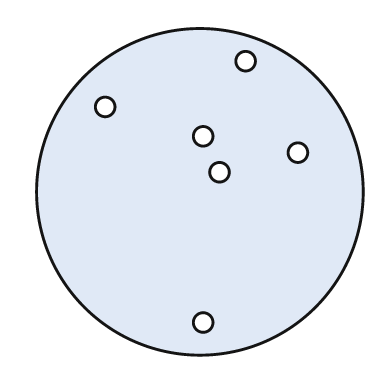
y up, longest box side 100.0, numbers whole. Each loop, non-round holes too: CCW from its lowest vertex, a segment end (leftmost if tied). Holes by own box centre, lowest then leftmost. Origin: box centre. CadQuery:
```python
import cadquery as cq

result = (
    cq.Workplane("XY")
    .moveTo(0.0, 0.0)
    .circle(50.0)
    .moveTo(1.0, -40.0)
    .circle(3.0)
    .moveTo(6.0, 6.0)
    .circle(3.0)
    .moveTo(30.0, 12.0)
    .circle(3.0)
    .moveTo(1.0, 17.0)
    .circle(3.0)
    .moveTo(-29.0, 26.0)
    .circle(3.0)
    .moveTo(14.0, 40.0)
    .circle(3.0)
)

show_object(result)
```